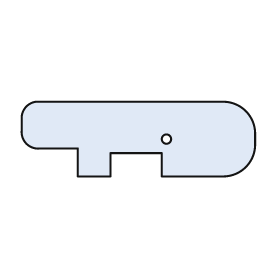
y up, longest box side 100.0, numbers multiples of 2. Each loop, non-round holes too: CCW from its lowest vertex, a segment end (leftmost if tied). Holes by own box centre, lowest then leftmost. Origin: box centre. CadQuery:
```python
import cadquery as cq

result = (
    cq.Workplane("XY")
    .moveTo(-26.0, -16.0)
    .lineTo(-12.0, -16.0)
    .lineTo(-12.0, -6.0)
    .lineTo(10.0, -6.0)
    .lineTo(10.0, -16.0)
    .lineTo(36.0, -16.0)
    .threePointArc((46.0, -12.0), (50.0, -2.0))
    .lineTo(50.0, 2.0)
    .threePointArc((46.0, 12.0), (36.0, 16.0))
    .lineTo(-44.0, 16.0)
    .threePointArc((-48.0, 14.0), (-50.0, 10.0))
    .lineTo(-50.0, 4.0)
    .threePointArc((-48.0, -2.0), (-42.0, -4.0))
    .lineTo(-26.0, -4.0)
    .close()
    .moveTo(12.0, 0.0)
    .circle(2.0)
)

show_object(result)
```